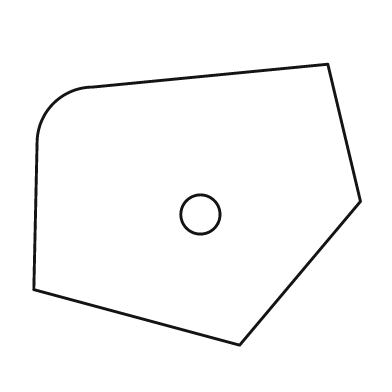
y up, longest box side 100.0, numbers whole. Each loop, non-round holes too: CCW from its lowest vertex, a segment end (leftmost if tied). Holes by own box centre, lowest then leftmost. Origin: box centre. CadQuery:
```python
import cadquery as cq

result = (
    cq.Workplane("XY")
    .moveTo(13.0, -43.0)
    .lineTo(50.0, 1.0)
    .lineTo(40.0, 43.0)
    .lineTo(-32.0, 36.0)
    .threePointArc((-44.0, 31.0), (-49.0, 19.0))
    .lineTo(-50.0, -26.0)
    .close()
    .moveTo(1.0, -3.0)
    .circle(6.0)
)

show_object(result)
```